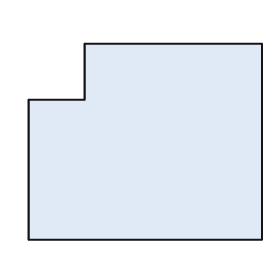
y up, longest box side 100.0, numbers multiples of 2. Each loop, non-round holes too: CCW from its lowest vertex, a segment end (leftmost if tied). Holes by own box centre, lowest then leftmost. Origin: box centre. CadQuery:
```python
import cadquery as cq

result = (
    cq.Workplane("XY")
    .moveTo(-50.0, -42.0)
    .lineTo(50.0, -42.0)
    .lineTo(50.0, 42.0)
    .lineTo(-26.0, 42.0)
    .lineTo(-26.0, 18.0)
    .lineTo(-50.0, 18.0)
    .close()
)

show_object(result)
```